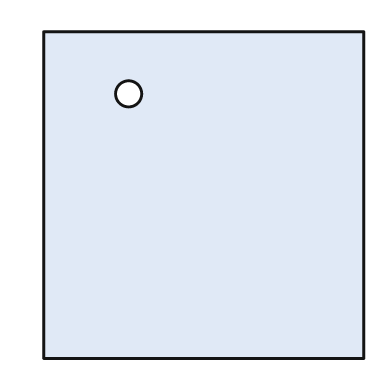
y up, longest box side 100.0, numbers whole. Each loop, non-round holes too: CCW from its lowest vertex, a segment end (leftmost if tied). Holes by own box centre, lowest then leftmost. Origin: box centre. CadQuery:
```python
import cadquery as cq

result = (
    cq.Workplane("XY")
    .moveTo(-49.0, -50.0)
    .lineTo(49.0, -50.0)
    .lineTo(49.0, 50.0)
    .lineTo(-49.0, 50.0)
    .close()
    .moveTo(-23.0, 31.0)
    .circle(4.0)
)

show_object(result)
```